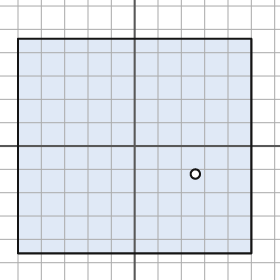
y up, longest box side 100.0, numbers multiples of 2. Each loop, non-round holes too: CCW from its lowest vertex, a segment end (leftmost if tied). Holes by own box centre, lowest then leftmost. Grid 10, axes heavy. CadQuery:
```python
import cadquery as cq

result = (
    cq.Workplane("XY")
    .moveTo(-50.0, -46.0)
    .lineTo(50.0, -46.0)
    .lineTo(50.0, 46.0)
    .lineTo(-50.0, 46.0)
    .close()
    .moveTo(26.0, -12.0)
    .circle(2.0)
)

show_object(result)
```